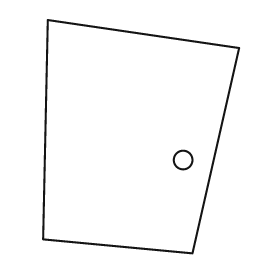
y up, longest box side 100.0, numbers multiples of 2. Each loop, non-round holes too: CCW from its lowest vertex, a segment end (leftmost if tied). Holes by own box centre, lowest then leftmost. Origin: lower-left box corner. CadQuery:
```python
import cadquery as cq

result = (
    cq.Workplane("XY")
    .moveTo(64.0, 0.0)
    .lineTo(84.0, 88.0)
    .lineTo(2.0, 100.0)
    .lineTo(0.0, 6.0)
    .close()
    .moveTo(60.0, 40.0)
    .circle(4.0)
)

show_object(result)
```